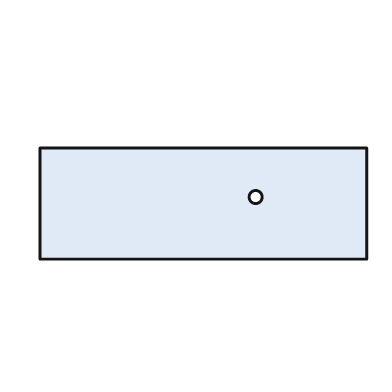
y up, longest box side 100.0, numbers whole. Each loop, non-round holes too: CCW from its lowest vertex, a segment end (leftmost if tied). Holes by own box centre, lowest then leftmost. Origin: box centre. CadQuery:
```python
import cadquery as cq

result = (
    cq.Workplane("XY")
    .moveTo(-50.0, -17.0)
    .lineTo(50.0, -17.0)
    .lineTo(50.0, 17.0)
    .lineTo(-50.0, 17.0)
    .close()
    .moveTo(16.0, 2.0)
    .circle(2.0)
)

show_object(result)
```